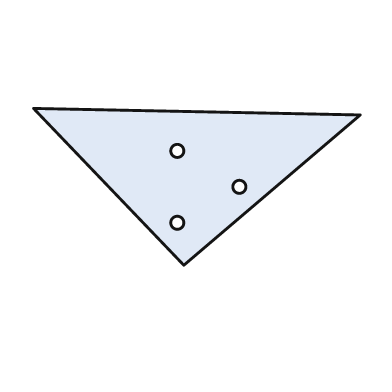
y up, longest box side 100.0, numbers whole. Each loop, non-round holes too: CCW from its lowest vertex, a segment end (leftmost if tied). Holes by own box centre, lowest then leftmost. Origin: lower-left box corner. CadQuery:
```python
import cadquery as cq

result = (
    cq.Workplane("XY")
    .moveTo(46.0, 0.0)
    .lineTo(100.0, 46.0)
    .lineTo(0.0, 48.0)
    .close()
    .moveTo(44.0, 13.0)
    .circle(2.0)
    .moveTo(63.0, 24.0)
    .circle(2.0)
    .moveTo(44.0, 35.0)
    .circle(2.0)
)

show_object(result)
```